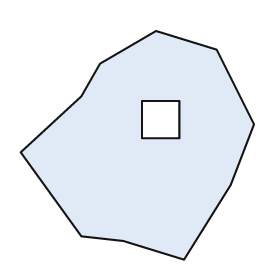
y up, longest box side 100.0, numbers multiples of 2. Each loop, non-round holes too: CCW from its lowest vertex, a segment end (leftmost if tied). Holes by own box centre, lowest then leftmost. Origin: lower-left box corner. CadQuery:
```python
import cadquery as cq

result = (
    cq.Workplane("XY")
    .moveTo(70.0, 0.0)
    .lineTo(90.0, 32.0)
    .lineTo(100.0, 58.0)
    .lineTo(84.0, 90.0)
    .lineTo(58.0, 98.0)
    .lineTo(34.0, 84.0)
    .lineTo(26.0, 70.0)
    .lineTo(0.0, 46.0)
    .lineTo(26.0, 10.0)
    .lineTo(44.0, 8.0)
    .close()
    .moveTo(52.0, 52.0)
    .lineTo(68.0, 52.0)
    .lineTo(68.0, 68.0)
    .lineTo(52.0, 68.0)
    .close()
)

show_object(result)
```